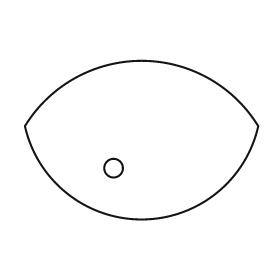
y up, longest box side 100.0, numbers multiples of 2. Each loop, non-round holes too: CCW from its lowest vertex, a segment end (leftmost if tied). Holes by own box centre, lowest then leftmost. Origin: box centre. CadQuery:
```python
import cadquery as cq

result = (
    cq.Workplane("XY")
    .moveTo(-50.0, 6.0)
    .threePointArc((0.0, -34.0), (50.0, 6.0))
    .threePointArc((0.0, 34.0), (-50.0, 6.0))
    .close()
    .moveTo(-12.0, -12.0)
    .circle(4.0)
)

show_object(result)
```